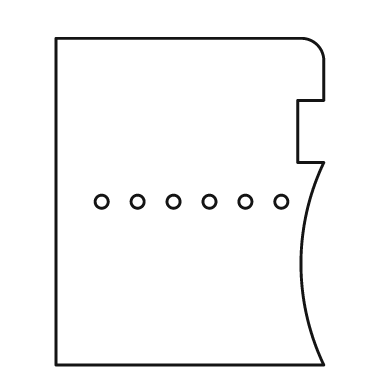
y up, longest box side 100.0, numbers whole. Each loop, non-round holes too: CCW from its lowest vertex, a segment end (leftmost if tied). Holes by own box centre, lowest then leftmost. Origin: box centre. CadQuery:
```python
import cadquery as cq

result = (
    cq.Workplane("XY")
    .moveTo(-41.0, -50.0)
    .lineTo(41.0, -50.0)
    .threePointArc((34.0, -19.0), (41.0, 12.0))
    .lineTo(33.0, 12.0)
    .lineTo(33.0, 31.0)
    .lineTo(41.0, 31.0)
    .lineTo(41.0, 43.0)
    .threePointArc((39.0, 48.0), (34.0, 50.0))
    .lineTo(-41.0, 50.0)
    .close()
    .moveTo(-27.0, 0.0)
    .circle(2.0)
    .moveTo(-16.0, 0.0)
    .circle(2.0)
    .moveTo(-5.0, 0.0)
    .circle(2.0)
    .moveTo(6.0, 0.0)
    .circle(2.0)
    .moveTo(17.0, 0.0)
    .circle(2.0)
    .moveTo(28.0, 0.0)
    .circle(2.0)
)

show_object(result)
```